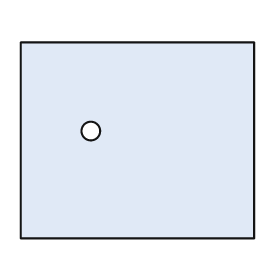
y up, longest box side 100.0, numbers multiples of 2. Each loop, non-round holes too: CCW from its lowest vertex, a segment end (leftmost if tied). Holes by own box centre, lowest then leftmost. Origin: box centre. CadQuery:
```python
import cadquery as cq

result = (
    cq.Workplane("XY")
    .moveTo(-50.0, -42.0)
    .lineTo(50.0, -42.0)
    .lineTo(50.0, 42.0)
    .lineTo(-50.0, 42.0)
    .close()
    .moveTo(-20.0, 4.0)
    .circle(4.0)
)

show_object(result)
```